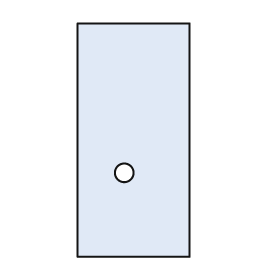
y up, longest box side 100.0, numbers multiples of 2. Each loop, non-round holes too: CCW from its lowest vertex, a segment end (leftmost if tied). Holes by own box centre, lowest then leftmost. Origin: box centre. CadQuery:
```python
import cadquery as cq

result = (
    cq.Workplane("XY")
    .moveTo(-24.0, -50.0)
    .lineTo(24.0, -50.0)
    .lineTo(24.0, 50.0)
    .lineTo(-24.0, 50.0)
    .close()
    .moveTo(-4.0, -14.0)
    .circle(4.0)
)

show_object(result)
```